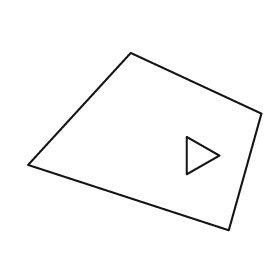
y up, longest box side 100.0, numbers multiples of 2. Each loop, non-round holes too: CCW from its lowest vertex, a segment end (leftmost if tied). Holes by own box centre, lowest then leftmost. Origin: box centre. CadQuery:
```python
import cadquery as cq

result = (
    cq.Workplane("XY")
    .moveTo(36.0, -38.0)
    .lineTo(50.0, 12.0)
    .lineTo(-6.0, 38.0)
    .lineTo(-50.0, -10.0)
    .close()
    .moveTo(18.0, -14.0)
    .lineTo(32.0, -6.0)
    .lineTo(18.0, 2.0)
    .close()
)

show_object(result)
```